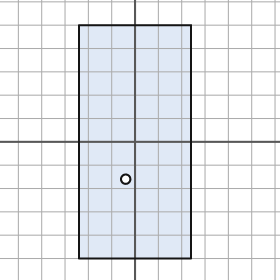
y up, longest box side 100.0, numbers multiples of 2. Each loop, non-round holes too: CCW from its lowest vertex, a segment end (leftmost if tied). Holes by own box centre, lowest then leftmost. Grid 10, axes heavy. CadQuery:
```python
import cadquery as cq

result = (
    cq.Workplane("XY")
    .moveTo(-24.0, -50.0)
    .lineTo(24.0, -50.0)
    .lineTo(24.0, 50.0)
    .lineTo(-24.0, 50.0)
    .close()
    .moveTo(-4.0, -16.0)
    .circle(2.0)
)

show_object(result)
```